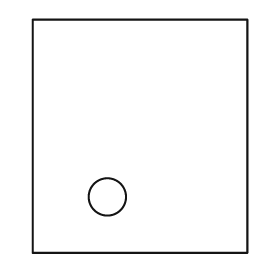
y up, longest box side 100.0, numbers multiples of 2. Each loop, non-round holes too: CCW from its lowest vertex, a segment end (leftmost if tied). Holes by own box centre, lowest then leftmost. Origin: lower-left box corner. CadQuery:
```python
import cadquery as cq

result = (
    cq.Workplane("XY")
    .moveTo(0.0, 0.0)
    .lineTo(92.0, 0.0)
    .lineTo(92.0, 100.0)
    .lineTo(0.0, 100.0)
    .close()
    .moveTo(32.0, 24.0)
    .circle(8.0)
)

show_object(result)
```